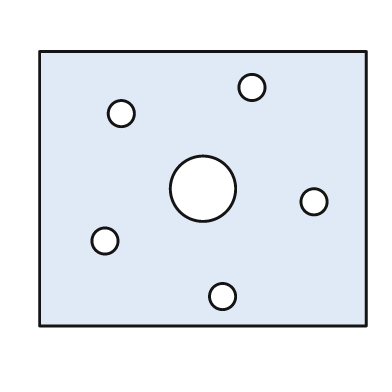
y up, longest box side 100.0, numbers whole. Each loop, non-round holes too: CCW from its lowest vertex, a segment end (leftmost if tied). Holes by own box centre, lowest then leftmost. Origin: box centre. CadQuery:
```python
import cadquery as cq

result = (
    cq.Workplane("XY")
    .moveTo(-50.0, -42.0)
    .lineTo(50.0, -42.0)
    .lineTo(50.0, 42.0)
    .lineTo(-50.0, 42.0)
    .close()
    .moveTo(6.0, -33.0)
    .circle(4.0)
    .moveTo(-30.0, -16.0)
    .circle(4.0)
    .moveTo(34.0, -4.0)
    .circle(4.0)
    .moveTo(0.0, 0.0)
    .circle(10.0)
    .moveTo(-25.0, 23.0)
    .circle(4.0)
    .moveTo(15.0, 31.0)
    .circle(4.0)
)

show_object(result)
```